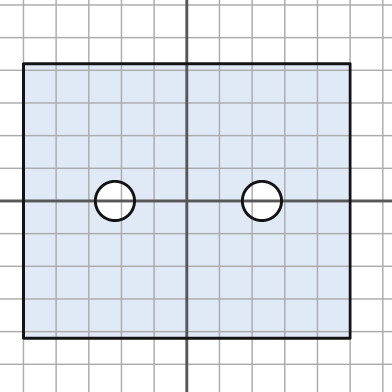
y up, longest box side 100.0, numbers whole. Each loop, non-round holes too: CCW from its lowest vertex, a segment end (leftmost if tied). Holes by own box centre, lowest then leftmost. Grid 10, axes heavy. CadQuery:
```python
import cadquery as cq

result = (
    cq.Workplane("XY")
    .moveTo(-50.0, -42.0)
    .lineTo(50.0, -42.0)
    .lineTo(50.0, 42.0)
    .lineTo(-50.0, 42.0)
    .close()
    .moveTo(-22.0, 0.0)
    .circle(6.0)
    .moveTo(23.0, 0.0)
    .circle(6.0)
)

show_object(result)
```